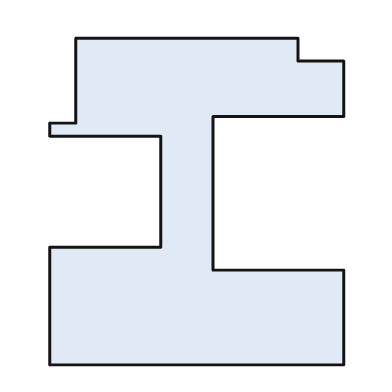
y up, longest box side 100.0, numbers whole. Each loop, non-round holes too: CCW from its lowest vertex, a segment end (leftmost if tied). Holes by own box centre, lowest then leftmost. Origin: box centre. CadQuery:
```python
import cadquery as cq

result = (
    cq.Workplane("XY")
    .moveTo(-45.0, -50.0)
    .lineTo(45.0, -50.0)
    .lineTo(45.0, -21.0)
    .lineTo(5.0, -21.0)
    .lineTo(5.0, 26.0)
    .lineTo(45.0, 26.0)
    .lineTo(45.0, 43.0)
    .lineTo(31.0, 43.0)
    .lineTo(31.0, 50.0)
    .lineTo(-37.0, 50.0)
    .lineTo(-37.0, 24.0)
    .lineTo(-45.0, 24.0)
    .lineTo(-45.0, 20.0)
    .lineTo(-11.0, 20.0)
    .lineTo(-11.0, -14.0)
    .lineTo(-45.0, -14.0)
    .close()
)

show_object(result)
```